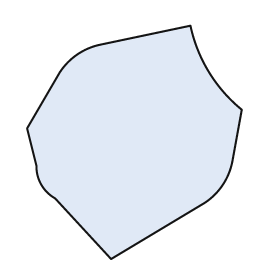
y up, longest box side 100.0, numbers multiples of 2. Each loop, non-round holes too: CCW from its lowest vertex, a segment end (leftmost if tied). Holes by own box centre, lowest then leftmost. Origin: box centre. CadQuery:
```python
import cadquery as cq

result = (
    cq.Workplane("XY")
    .moveTo(-10.0, -50.0)
    .lineTo(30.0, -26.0)
    .threePointArc((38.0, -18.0), (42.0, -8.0))
    .lineTo(46.0, 14.0)
    .threePointArc((32.0, 30.0), (24.0, 50.0))
    .lineTo(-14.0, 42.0)
    .threePointArc((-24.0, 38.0), (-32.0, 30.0))
    .lineTo(-46.0, 6.0)
    .lineTo(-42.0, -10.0)
    .threePointArc((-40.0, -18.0), (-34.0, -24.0))
    .close()
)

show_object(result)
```